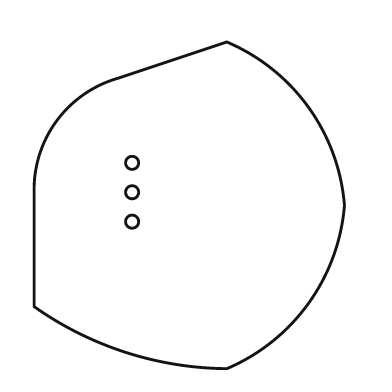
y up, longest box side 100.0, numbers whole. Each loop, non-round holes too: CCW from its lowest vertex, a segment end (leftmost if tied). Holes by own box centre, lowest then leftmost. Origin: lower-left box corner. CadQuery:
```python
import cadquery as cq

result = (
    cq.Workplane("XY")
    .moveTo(59.0, 0.0)
    .threePointArc((84.0, 20.0), (95.0, 50.0))
    .threePointArc((84.0, 80.0), (59.0, 100.0))
    .lineTo(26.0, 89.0)
    .threePointArc((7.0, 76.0), (0.0, 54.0))
    .lineTo(0.0, 19.0)
    .threePointArc((28.0, 5.0), (59.0, 0.0))
    .close()
    .moveTo(30.0, 45.0)
    .circle(2.0)
    .moveTo(30.0, 54.0)
    .circle(2.0)
    .moveTo(30.0, 63.0)
    .circle(2.0)
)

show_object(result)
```